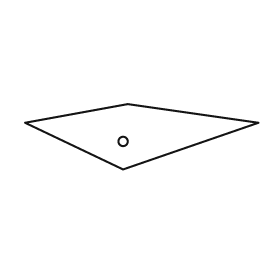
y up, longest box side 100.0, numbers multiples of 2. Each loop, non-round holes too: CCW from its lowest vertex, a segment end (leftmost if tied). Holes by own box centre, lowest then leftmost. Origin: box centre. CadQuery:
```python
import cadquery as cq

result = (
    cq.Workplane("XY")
    .moveTo(-8.0, -14.0)
    .lineTo(50.0, 6.0)
    .lineTo(-6.0, 14.0)
    .lineTo(-50.0, 6.0)
    .close()
    .moveTo(-8.0, -2.0)
    .circle(2.0)
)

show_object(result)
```